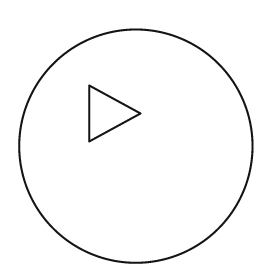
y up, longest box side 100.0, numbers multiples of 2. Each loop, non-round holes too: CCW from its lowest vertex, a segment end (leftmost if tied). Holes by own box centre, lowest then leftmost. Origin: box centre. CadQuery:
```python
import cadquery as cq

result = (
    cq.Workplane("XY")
    .moveTo(0.0, 0.0)
    .circle(50.0)
    .moveTo(-20.0, 2.0)
    .lineTo(2.0, 14.0)
    .lineTo(-20.0, 26.0)
    .close()
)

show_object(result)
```